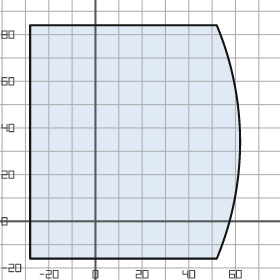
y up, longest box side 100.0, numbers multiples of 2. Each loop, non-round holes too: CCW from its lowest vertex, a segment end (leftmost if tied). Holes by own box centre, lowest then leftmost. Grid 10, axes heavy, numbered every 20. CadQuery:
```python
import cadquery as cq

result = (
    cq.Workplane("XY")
    .moveTo(-28.0, -16.0)
    .lineTo(52.0, -16.0)
    .threePointArc((62.0, 34.0), (52.0, 84.0))
    .lineTo(-28.0, 84.0)
    .close()
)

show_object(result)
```